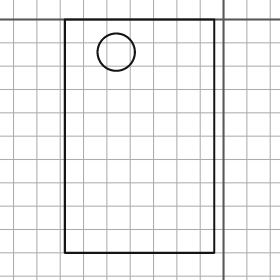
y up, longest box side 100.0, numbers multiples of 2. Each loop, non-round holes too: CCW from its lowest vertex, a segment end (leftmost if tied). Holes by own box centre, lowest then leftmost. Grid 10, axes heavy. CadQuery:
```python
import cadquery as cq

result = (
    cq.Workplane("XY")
    .moveTo(-68.0, -100.0)
    .lineTo(-4.0, -100.0)
    .lineTo(-4.0, 0.0)
    .lineTo(-68.0, 0.0)
    .close()
    .moveTo(-46.0, -14.0)
    .circle(8.0)
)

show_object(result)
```